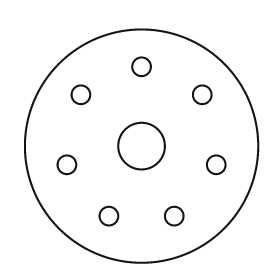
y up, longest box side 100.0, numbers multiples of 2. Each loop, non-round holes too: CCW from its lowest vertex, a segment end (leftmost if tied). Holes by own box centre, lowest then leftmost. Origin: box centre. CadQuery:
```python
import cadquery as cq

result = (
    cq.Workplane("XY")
    .moveTo(0.0, 0.0)
    .circle(50.0)
    .moveTo(-14.0, -30.0)
    .circle(4.0)
    .moveTo(14.0, -30.0)
    .circle(4.0)
    .moveTo(-32.0, -8.0)
    .circle(4.0)
    .moveTo(32.0, -8.0)
    .circle(4.0)
    .moveTo(0.0, 0.0)
    .circle(10.0)
    .moveTo(-26.0, 22.0)
    .circle(4.0)
    .moveTo(26.0, 22.0)
    .circle(4.0)
    .moveTo(0.0, 34.0)
    .circle(4.0)
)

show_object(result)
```